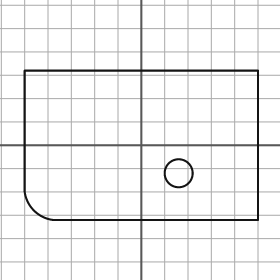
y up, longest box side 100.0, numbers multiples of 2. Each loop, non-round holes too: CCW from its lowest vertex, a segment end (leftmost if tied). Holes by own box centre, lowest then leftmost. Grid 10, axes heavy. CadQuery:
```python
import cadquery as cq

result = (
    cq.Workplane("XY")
    .moveTo(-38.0, -32.0)
    .lineTo(50.0, -32.0)
    .lineTo(50.0, 32.0)
    .lineTo(-50.0, 32.0)
    .lineTo(-50.0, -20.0)
    .threePointArc((-46.0, -28.0), (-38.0, -32.0))
    .close()
    .moveTo(16.0, -12.0)
    .circle(6.0)
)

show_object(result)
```